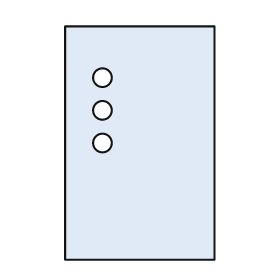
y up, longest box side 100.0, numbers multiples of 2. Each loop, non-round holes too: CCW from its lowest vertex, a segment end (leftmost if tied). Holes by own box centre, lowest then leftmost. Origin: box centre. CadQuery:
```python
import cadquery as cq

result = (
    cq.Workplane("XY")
    .moveTo(-32.0, -50.0)
    .lineTo(32.0, -50.0)
    .lineTo(32.0, 50.0)
    .lineTo(-32.0, 50.0)
    .close()
    .moveTo(-16.0, 0.0)
    .circle(4.0)
    .moveTo(-16.0, 14.0)
    .circle(4.0)
    .moveTo(-16.0, 28.0)
    .circle(4.0)
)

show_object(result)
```